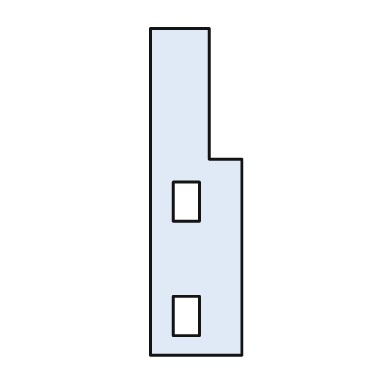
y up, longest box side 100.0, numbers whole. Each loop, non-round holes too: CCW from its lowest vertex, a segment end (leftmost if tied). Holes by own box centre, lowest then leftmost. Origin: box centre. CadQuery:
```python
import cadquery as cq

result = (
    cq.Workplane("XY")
    .moveTo(-14.0, -50.0)
    .lineTo(14.0, -50.0)
    .lineTo(14.0, 10.0)
    .lineTo(4.0, 10.0)
    .lineTo(4.0, 50.0)
    .lineTo(-14.0, 50.0)
    .close()
    .moveTo(-7.0, -44.0)
    .lineTo(1.0, -44.0)
    .lineTo(1.0, -32.0)
    .lineTo(-7.0, -32.0)
    .close()
    .moveTo(-7.0, -9.0)
    .lineTo(1.0, -9.0)
    .lineTo(1.0, 3.0)
    .lineTo(-7.0, 3.0)
    .close()
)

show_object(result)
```